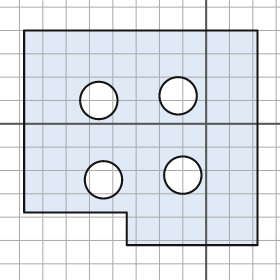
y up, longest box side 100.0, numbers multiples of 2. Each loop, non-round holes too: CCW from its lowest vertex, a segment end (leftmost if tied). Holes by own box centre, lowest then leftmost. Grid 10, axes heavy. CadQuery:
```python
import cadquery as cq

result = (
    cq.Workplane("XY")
    .moveTo(-34.0, -52.0)
    .lineTo(22.0, -52.0)
    .lineTo(22.0, 40.0)
    .lineTo(-78.0, 40.0)
    .lineTo(-78.0, -38.0)
    .lineTo(-34.0, -38.0)
    .close()
    .moveTo(-44.0, -24.0)
    .circle(8.0)
    .moveTo(-10.0, -22.0)
    .circle(8.0)
    .moveTo(-46.0, 10.0)
    .circle(8.0)
    .moveTo(-12.0, 12.0)
    .circle(8.0)
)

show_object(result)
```